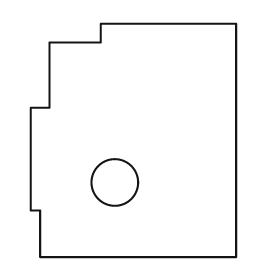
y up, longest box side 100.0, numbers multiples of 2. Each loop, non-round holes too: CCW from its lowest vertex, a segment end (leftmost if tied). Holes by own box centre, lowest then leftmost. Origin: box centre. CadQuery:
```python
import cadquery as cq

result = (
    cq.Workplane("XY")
    .moveTo(-40.0, -50.0)
    .lineTo(44.0, -50.0)
    .lineTo(44.0, 50.0)
    .lineTo(-14.0, 50.0)
    .lineTo(-14.0, 42.0)
    .lineTo(-36.0, 42.0)
    .lineTo(-36.0, 14.0)
    .lineTo(-44.0, 14.0)
    .lineTo(-44.0, -30.0)
    .lineTo(-40.0, -30.0)
    .close()
    .moveTo(-8.0, -18.0)
    .circle(10.0)
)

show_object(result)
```